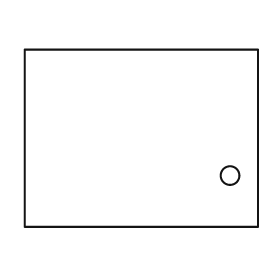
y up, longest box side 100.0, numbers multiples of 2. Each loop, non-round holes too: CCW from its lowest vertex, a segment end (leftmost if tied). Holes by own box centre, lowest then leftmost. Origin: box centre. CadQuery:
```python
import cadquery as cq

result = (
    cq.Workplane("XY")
    .moveTo(-50.0, -38.0)
    .lineTo(50.0, -38.0)
    .lineTo(50.0, 38.0)
    .lineTo(-50.0, 38.0)
    .close()
    .moveTo(38.0, -16.0)
    .circle(4.0)
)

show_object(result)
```